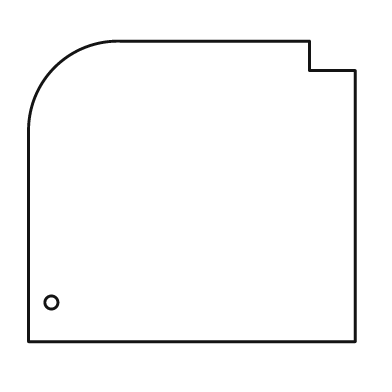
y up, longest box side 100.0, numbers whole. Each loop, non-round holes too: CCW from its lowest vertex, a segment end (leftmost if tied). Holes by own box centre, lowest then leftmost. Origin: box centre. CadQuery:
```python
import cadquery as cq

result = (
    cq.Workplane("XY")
    .moveTo(-50.0, -46.0)
    .lineTo(50.0, -46.0)
    .lineTo(50.0, 37.0)
    .lineTo(36.0, 37.0)
    .lineTo(36.0, 46.0)
    .lineTo(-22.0, 46.0)
    .threePointArc((-42.0, 38.0), (-50.0, 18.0))
    .close()
    .moveTo(-43.0, -34.0)
    .circle(2.0)
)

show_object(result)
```